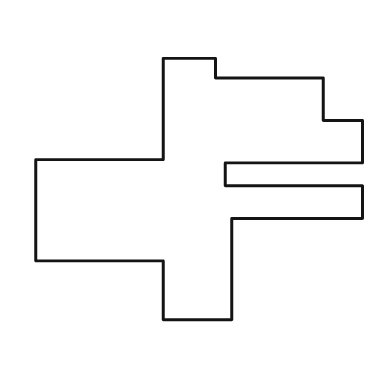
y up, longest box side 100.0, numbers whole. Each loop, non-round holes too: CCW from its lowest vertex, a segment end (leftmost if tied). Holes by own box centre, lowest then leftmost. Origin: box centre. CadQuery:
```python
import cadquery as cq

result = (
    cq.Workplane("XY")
    .moveTo(-11.0, -40.0)
    .lineTo(10.0, -40.0)
    .lineTo(10.0, -9.0)
    .lineTo(50.0, -9.0)
    .lineTo(50.0, 1.0)
    .lineTo(8.0, 1.0)
    .lineTo(8.0, 8.0)
    .lineTo(50.0, 8.0)
    .lineTo(50.0, 21.0)
    .lineTo(38.0, 21.0)
    .lineTo(38.0, 34.0)
    .lineTo(5.0, 34.0)
    .lineTo(5.0, 40.0)
    .lineTo(-11.0, 40.0)
    .lineTo(-11.0, 9.0)
    .lineTo(-50.0, 9.0)
    .lineTo(-50.0, -22.0)
    .lineTo(-11.0, -22.0)
    .close()
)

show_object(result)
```